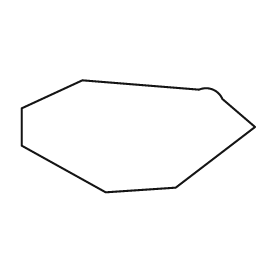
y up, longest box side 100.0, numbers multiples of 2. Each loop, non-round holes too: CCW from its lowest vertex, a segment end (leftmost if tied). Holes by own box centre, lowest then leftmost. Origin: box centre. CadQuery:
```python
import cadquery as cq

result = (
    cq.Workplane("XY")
    .moveTo(-14.0, -24.0)
    .lineTo(16.0, -22.0)
    .lineTo(50.0, 4.0)
    .lineTo(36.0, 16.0)
    .threePointArc((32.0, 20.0), (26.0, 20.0))
    .lineTo(-24.0, 24.0)
    .lineTo(-50.0, 12.0)
    .lineTo(-50.0, -4.0)
    .close()
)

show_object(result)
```